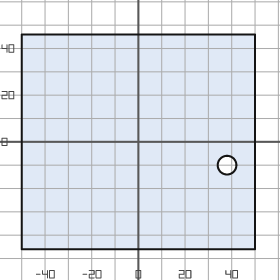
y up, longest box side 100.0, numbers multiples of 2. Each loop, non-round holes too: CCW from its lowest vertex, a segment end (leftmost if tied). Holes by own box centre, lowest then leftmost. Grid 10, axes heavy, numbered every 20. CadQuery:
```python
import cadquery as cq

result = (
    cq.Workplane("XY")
    .moveTo(-50.0, -46.0)
    .lineTo(50.0, -46.0)
    .lineTo(50.0, 46.0)
    .lineTo(-50.0, 46.0)
    .close()
    .moveTo(38.0, -10.0)
    .circle(4.0)
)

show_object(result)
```